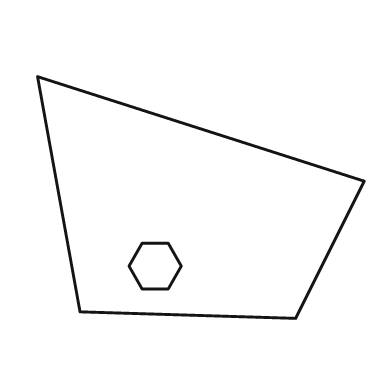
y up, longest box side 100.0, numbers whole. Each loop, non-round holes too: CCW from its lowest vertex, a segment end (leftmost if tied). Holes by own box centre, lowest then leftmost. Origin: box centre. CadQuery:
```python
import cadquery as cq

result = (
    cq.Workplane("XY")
    .moveTo(29.0, -37.0)
    .lineTo(50.0, 5.0)
    .lineTo(-50.0, 37.0)
    .lineTo(-37.0, -35.0)
    .close()
    .moveTo(-18.0, -28.0)
    .lineTo(-10.0, -28.0)
    .lineTo(-6.0, -21.0)
    .lineTo(-10.0, -14.0)
    .lineTo(-18.0, -14.0)
    .lineTo(-22.0, -21.0)
    .close()
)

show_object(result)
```